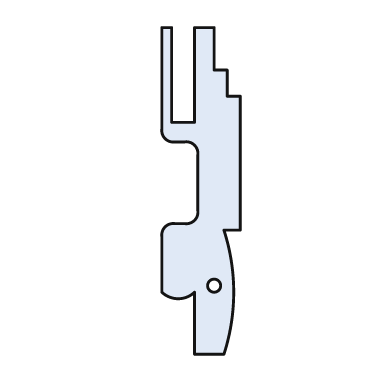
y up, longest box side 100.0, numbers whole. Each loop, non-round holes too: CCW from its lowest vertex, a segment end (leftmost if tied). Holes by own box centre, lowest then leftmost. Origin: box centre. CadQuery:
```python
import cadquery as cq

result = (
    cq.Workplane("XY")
    .moveTo(-2.0, -50.0)
    .lineTo(7.0, -50.0)
    .threePointArc((10.0, -31.0), (7.0, -12.0))
    .lineTo(12.0, -12.0)
    .lineTo(12.0, 29.0)
    .lineTo(8.0, 29.0)
    .lineTo(8.0, 37.0)
    .lineTo(4.0, 37.0)
    .lineTo(4.0, 50.0)
    .lineTo(-2.0, 50.0)
    .lineTo(-2.0, 21.0)
    .lineTo(-9.0, 21.0)
    .lineTo(-9.0, 50.0)
    .lineTo(-12.0, 50.0)
    .lineTo(-12.0, 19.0)
    .threePointArc((-11.0, 16.0), (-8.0, 15.0))
    .lineTo(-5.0, 15.0)
    .threePointArc((-2.0, 14.0), (-1.0, 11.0))
    .lineTo(-1.0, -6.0)
    .threePointArc((-2.0, -9.0), (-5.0, -10.0))
    .lineTo(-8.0, -10.0)
    .threePointArc((-11.0, -11.0), (-12.0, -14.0))
    .lineTo(-12.0, -31.0)
    .threePointArc((-7.0, -33.0), (-2.0, -31.0))
    .close()
    .moveTo(4.0, -29.0)
    .circle(2.0)
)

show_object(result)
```